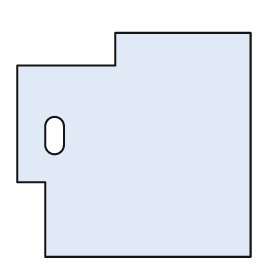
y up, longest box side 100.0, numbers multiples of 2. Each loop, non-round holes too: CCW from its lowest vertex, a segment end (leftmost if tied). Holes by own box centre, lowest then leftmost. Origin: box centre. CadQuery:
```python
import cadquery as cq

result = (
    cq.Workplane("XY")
    .moveTo(-38.0, -48.0)
    .lineTo(50.0, -48.0)
    .lineTo(50.0, 48.0)
    .lineTo(-8.0, 48.0)
    .lineTo(-8.0, 34.0)
    .lineTo(-50.0, 34.0)
    .lineTo(-50.0, -16.0)
    .lineTo(-38.0, -16.0)
    .close()
    .moveTo(-38.0, 0.0)
    .threePointArc((-34.0, -4.0), (-30.0, 0.0))
    .lineTo(-30.0, 8.0)
    .threePointArc((-34.0, 12.0), (-38.0, 8.0))
    .close()
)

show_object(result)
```